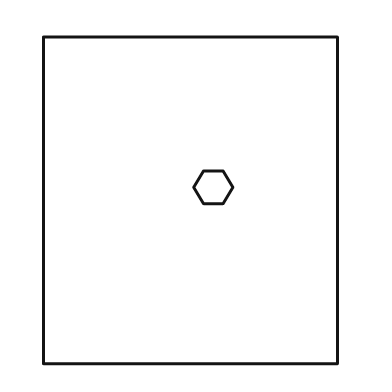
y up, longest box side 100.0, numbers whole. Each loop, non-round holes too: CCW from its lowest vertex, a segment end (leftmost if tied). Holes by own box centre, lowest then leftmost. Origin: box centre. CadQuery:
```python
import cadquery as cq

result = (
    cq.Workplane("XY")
    .moveTo(-45.0, -50.0)
    .lineTo(45.0, -50.0)
    .lineTo(45.0, 50.0)
    .lineTo(-45.0, 50.0)
    .close()
    .moveTo(4.0, -1.0)
    .lineTo(10.0, -1.0)
    .lineTo(13.0, 4.0)
    .lineTo(10.0, 9.0)
    .lineTo(4.0, 9.0)
    .lineTo(1.0, 4.0)
    .close()
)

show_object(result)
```